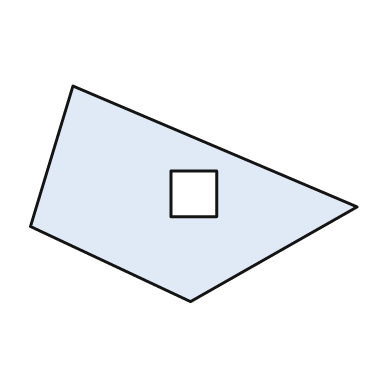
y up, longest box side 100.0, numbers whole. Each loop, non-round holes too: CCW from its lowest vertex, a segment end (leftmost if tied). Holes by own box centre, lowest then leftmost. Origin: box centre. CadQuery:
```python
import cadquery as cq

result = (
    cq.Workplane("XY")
    .moveTo(-1.0, -33.0)
    .lineTo(50.0, -4.0)
    .lineTo(-37.0, 33.0)
    .lineTo(-50.0, -10.0)
    .close()
    .moveTo(-7.0, -7.0)
    .lineTo(7.0, -7.0)
    .lineTo(7.0, 7.0)
    .lineTo(-7.0, 7.0)
    .close()
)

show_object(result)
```